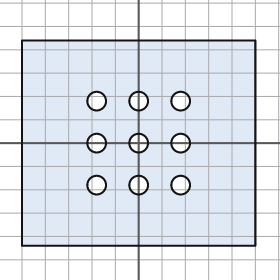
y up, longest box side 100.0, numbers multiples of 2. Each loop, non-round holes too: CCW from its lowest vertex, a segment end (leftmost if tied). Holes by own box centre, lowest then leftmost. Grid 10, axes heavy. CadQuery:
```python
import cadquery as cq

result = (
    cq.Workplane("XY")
    .moveTo(-50.0, -44.0)
    .lineTo(50.0, -44.0)
    .lineTo(50.0, 44.0)
    .lineTo(-50.0, 44.0)
    .close()
    .moveTo(-18.0, -18.0)
    .circle(4.0)
    .moveTo(0.0, -18.0)
    .circle(4.0)
    .moveTo(18.0, -18.0)
    .circle(4.0)
    .moveTo(-18.0, 0.0)
    .circle(4.0)
    .moveTo(0.0, 0.0)
    .circle(4.0)
    .moveTo(18.0, 0.0)
    .circle(4.0)
    .moveTo(-18.0, 18.0)
    .circle(4.0)
    .moveTo(0.0, 18.0)
    .circle(4.0)
    .moveTo(18.0, 18.0)
    .circle(4.0)
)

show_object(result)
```